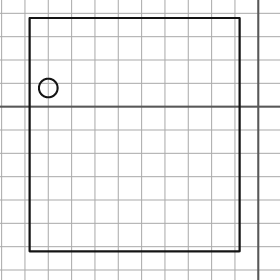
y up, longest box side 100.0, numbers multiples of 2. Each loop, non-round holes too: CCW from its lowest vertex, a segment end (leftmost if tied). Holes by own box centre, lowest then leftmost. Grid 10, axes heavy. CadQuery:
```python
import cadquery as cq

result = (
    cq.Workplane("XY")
    .moveTo(-98.0, -62.0)
    .lineTo(-8.0, -62.0)
    .lineTo(-8.0, 38.0)
    .lineTo(-98.0, 38.0)
    .close()
    .moveTo(-90.0, 8.0)
    .circle(4.0)
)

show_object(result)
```